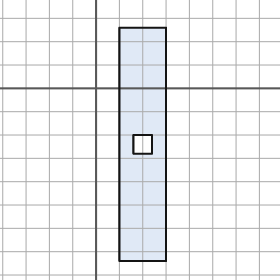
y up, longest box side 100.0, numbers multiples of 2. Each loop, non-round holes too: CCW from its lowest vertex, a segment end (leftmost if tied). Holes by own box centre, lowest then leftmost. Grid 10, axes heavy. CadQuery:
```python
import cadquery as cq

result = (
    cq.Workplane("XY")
    .moveTo(10.0, -74.0)
    .lineTo(30.0, -74.0)
    .lineTo(30.0, 26.0)
    .lineTo(10.0, 26.0)
    .close()
    .moveTo(16.0, -28.0)
    .lineTo(24.0, -28.0)
    .lineTo(24.0, -20.0)
    .lineTo(16.0, -20.0)
    .close()
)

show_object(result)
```